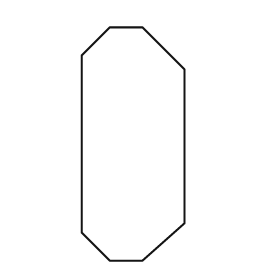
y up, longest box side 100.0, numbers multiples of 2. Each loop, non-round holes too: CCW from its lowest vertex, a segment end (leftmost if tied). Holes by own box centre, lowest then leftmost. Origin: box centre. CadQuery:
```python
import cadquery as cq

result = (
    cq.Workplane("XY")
    .moveTo(-10.0, -50.0)
    .lineTo(4.0, -50.0)
    .lineTo(22.0, -34.0)
    .lineTo(22.0, 32.0)
    .lineTo(4.0, 50.0)
    .lineTo(-10.0, 50.0)
    .lineTo(-22.0, 38.0)
    .lineTo(-22.0, -38.0)
    .close()
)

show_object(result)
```